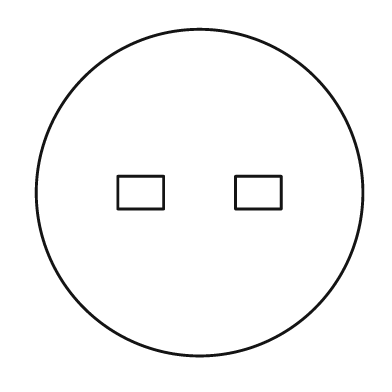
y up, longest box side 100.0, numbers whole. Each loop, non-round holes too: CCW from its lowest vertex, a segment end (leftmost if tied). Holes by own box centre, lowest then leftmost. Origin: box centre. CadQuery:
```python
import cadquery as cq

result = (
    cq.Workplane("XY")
    .moveTo(0.0, 0.0)
    .circle(50.0)
    .moveTo(-25.0, -5.0)
    .lineTo(-11.0, -5.0)
    .lineTo(-11.0, 5.0)
    .lineTo(-25.0, 5.0)
    .close()
    .moveTo(11.0, -5.0)
    .lineTo(25.0, -5.0)
    .lineTo(25.0, 5.0)
    .lineTo(11.0, 5.0)
    .close()
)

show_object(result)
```